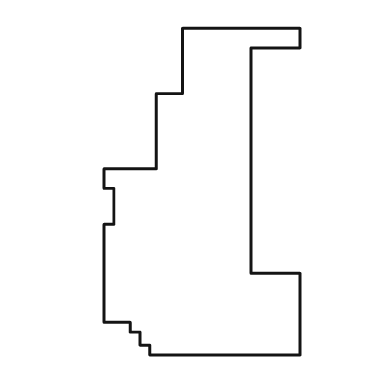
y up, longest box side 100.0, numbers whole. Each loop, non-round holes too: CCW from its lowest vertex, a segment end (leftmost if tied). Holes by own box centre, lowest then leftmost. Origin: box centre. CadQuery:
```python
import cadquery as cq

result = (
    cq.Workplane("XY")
    .moveTo(-16.0, -50.0)
    .lineTo(30.0, -50.0)
    .lineTo(30.0, -25.0)
    .lineTo(15.0, -25.0)
    .lineTo(15.0, 44.0)
    .lineTo(30.0, 44.0)
    .lineTo(30.0, 50.0)
    .lineTo(-6.0, 50.0)
    .lineTo(-6.0, 30.0)
    .lineTo(-14.0, 30.0)
    .lineTo(-14.0, 7.0)
    .lineTo(-30.0, 7.0)
    .lineTo(-30.0, 1.0)
    .lineTo(-27.0, 1.0)
    .lineTo(-27.0, -10.0)
    .lineTo(-30.0, -10.0)
    .lineTo(-30.0, -40.0)
    .lineTo(-22.0, -40.0)
    .lineTo(-22.0, -43.0)
    .lineTo(-19.0, -43.0)
    .lineTo(-19.0, -47.0)
    .lineTo(-16.0, -47.0)
    .close()
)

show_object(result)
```